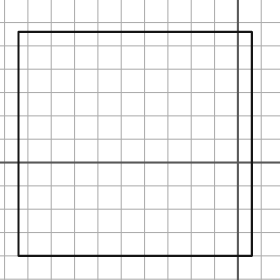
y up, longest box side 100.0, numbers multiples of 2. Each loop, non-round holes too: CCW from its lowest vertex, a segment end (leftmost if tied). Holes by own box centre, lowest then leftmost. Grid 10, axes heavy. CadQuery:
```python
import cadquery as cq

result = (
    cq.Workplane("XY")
    .moveTo(-94.0, -40.0)
    .lineTo(6.0, -40.0)
    .lineTo(6.0, 56.0)
    .lineTo(-94.0, 56.0)
    .close()
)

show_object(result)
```